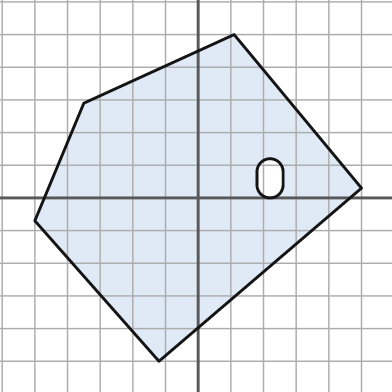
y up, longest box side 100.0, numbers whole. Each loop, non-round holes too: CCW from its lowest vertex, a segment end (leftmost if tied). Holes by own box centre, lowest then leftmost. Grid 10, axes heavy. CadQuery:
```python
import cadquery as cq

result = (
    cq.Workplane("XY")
    .moveTo(-12.0, -50.0)
    .lineTo(50.0, 3.0)
    .lineTo(11.0, 50.0)
    .lineTo(-35.0, 29.0)
    .lineTo(-50.0, -7.0)
    .close()
    .moveTo(18.0, 4.0)
    .threePointArc((22.0, 0.0), (26.0, 4.0))
    .lineTo(26.0, 8.0)
    .threePointArc((22.0, 12.0), (18.0, 8.0))
    .close()
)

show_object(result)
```